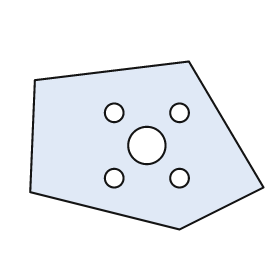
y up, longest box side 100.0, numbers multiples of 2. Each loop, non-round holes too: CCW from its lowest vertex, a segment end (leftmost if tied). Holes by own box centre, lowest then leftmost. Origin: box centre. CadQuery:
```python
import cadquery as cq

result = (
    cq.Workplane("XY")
    .moveTo(14.0, -36.0)
    .lineTo(50.0, -18.0)
    .lineTo(18.0, 36.0)
    .lineTo(-48.0, 28.0)
    .lineTo(-50.0, -20.0)
    .close()
    .moveTo(-14.0, -14.0)
    .circle(4.0)
    .moveTo(14.0, -14.0)
    .circle(4.0)
    .moveTo(0.0, 0.0)
    .circle(8.0)
    .moveTo(-14.0, 14.0)
    .circle(4.0)
    .moveTo(14.0, 14.0)
    .circle(4.0)
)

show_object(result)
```